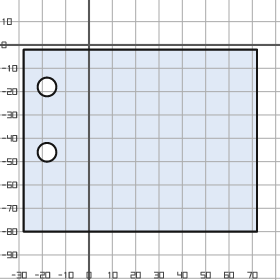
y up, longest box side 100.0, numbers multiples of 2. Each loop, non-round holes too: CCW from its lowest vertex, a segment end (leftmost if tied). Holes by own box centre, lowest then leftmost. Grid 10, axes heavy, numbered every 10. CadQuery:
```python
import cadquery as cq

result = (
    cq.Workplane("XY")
    .moveTo(-28.0, -80.0)
    .lineTo(72.0, -80.0)
    .lineTo(72.0, -2.0)
    .lineTo(-28.0, -2.0)
    .close()
    .moveTo(-18.0, -46.0)
    .circle(4.0)
    .moveTo(-18.0, -18.0)
    .circle(4.0)
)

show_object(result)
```